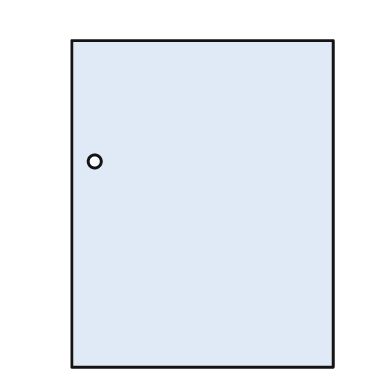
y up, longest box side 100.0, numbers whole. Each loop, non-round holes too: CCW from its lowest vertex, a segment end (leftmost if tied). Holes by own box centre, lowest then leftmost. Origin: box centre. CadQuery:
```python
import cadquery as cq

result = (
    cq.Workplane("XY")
    .moveTo(-40.0, -50.0)
    .lineTo(40.0, -50.0)
    .lineTo(40.0, 50.0)
    .lineTo(-40.0, 50.0)
    .close()
    .moveTo(-33.0, 13.0)
    .circle(2.0)
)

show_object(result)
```